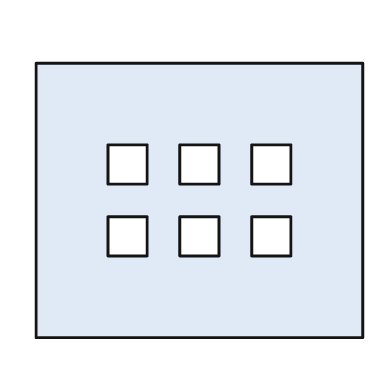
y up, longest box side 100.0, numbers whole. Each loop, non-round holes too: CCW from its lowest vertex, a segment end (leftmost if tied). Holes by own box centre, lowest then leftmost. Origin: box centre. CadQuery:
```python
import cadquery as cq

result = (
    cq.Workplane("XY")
    .moveTo(-50.0, -42.0)
    .lineTo(50.0, -42.0)
    .lineTo(50.0, 42.0)
    .lineTo(-50.0, 42.0)
    .close()
    .moveTo(-28.0, -17.0)
    .lineTo(-16.0, -17.0)
    .lineTo(-16.0, -5.0)
    .lineTo(-28.0, -5.0)
    .close()
    .moveTo(-6.0, -17.0)
    .lineTo(6.0, -17.0)
    .lineTo(6.0, -5.0)
    .lineTo(-6.0, -5.0)
    .close()
    .moveTo(16.0, -17.0)
    .lineTo(28.0, -17.0)
    .lineTo(28.0, -5.0)
    .lineTo(16.0, -5.0)
    .close()
    .moveTo(-28.0, 5.0)
    .lineTo(-16.0, 5.0)
    .lineTo(-16.0, 17.0)
    .lineTo(-28.0, 17.0)
    .close()
    .moveTo(-6.0, 5.0)
    .lineTo(6.0, 5.0)
    .lineTo(6.0, 17.0)
    .lineTo(-6.0, 17.0)
    .close()
    .moveTo(16.0, 5.0)
    .lineTo(28.0, 5.0)
    .lineTo(28.0, 17.0)
    .lineTo(16.0, 17.0)
    .close()
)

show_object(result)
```